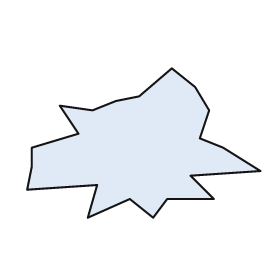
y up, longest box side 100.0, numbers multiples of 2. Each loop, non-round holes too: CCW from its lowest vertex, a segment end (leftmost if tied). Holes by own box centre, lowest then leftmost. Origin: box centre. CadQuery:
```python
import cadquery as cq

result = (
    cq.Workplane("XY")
    .moveTo(-24.0, -32.0)
    .lineTo(-6.0, -24.0)
    .lineTo(4.0, -32.0)
    .lineTo(10.0, -24.0)
    .lineTo(30.0, -24.0)
    .lineTo(20.0, -14.0)
    .lineTo(50.0, -12.0)
    .lineTo(34.0, -2.0)
    .lineTo(24.0, 2.0)
    .lineTo(28.0, 14.0)
    .lineTo(22.0, 24.0)
    .lineTo(12.0, 32.0)
    .lineTo(-2.0, 20.0)
    .lineTo(-12.0, 18.0)
    .lineTo(-22.0, 14.0)
    .lineTo(-36.0, 16.0)
    .lineTo(-28.0, 4.0)
    .lineTo(-48.0, -2.0)
    .lineTo(-48.0, -10.0)
    .lineTo(-50.0, -20.0)
    .lineTo(-20.0, -18.0)
    .close()
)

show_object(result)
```